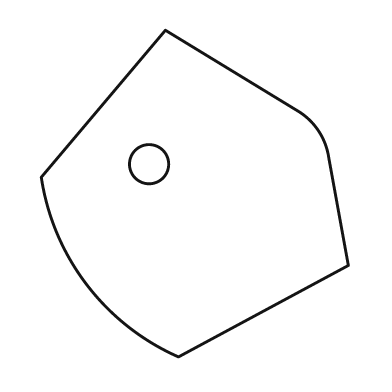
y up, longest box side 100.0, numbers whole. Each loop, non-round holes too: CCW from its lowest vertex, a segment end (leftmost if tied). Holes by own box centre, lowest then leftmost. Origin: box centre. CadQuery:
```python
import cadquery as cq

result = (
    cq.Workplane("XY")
    .moveTo(-5.0, -50.0)
    .lineTo(47.0, -22.0)
    .lineTo(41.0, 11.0)
    .threePointArc((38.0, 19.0), (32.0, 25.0))
    .lineTo(-9.0, 50.0)
    .lineTo(-47.0, 5.0)
    .threePointArc((-33.0, -28.0), (-5.0, -50.0))
    .close()
    .moveTo(-14.0, 9.0)
    .circle(6.0)
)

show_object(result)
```